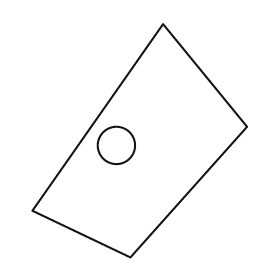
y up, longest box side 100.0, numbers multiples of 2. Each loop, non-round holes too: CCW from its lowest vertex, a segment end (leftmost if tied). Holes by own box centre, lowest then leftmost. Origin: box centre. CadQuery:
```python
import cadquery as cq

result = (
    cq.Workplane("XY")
    .moveTo(-4.0, -50.0)
    .lineTo(46.0, 6.0)
    .lineTo(10.0, 50.0)
    .lineTo(-46.0, -30.0)
    .close()
    .moveTo(-10.0, -2.0)
    .circle(8.0)
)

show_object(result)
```